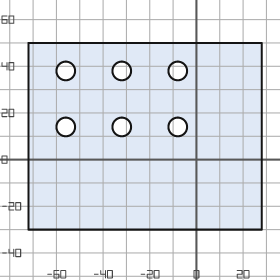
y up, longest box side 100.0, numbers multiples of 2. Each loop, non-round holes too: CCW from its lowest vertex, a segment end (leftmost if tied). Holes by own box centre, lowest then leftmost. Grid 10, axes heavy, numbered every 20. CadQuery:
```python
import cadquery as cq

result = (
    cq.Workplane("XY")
    .moveTo(-72.0, -30.0)
    .lineTo(28.0, -30.0)
    .lineTo(28.0, 50.0)
    .lineTo(-72.0, 50.0)
    .close()
    .moveTo(-56.0, 14.0)
    .circle(4.0)
    .moveTo(-32.0, 14.0)
    .circle(4.0)
    .moveTo(-8.0, 14.0)
    .circle(4.0)
    .moveTo(-56.0, 38.0)
    .circle(4.0)
    .moveTo(-32.0, 38.0)
    .circle(4.0)
    .moveTo(-8.0, 38.0)
    .circle(4.0)
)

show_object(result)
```